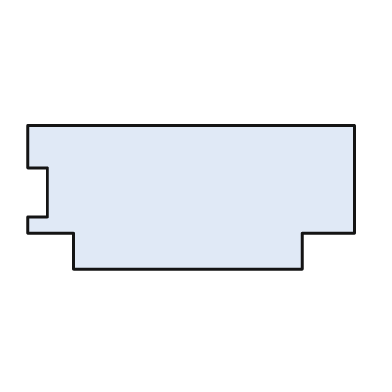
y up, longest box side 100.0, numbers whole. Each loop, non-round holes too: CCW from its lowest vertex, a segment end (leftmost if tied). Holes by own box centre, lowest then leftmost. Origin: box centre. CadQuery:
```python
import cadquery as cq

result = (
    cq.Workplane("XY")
    .moveTo(-36.0, -22.0)
    .lineTo(34.0, -22.0)
    .lineTo(34.0, -11.0)
    .lineTo(50.0, -11.0)
    .lineTo(50.0, 22.0)
    .lineTo(-50.0, 22.0)
    .lineTo(-50.0, 9.0)
    .lineTo(-44.0, 9.0)
    .lineTo(-44.0, -6.0)
    .lineTo(-50.0, -6.0)
    .lineTo(-50.0, -11.0)
    .lineTo(-36.0, -11.0)
    .close()
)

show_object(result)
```